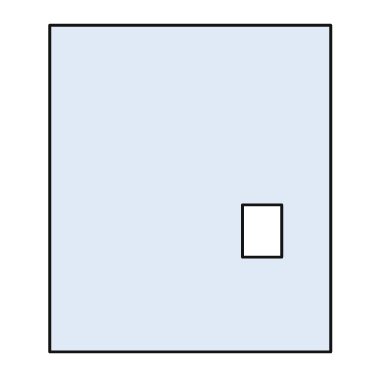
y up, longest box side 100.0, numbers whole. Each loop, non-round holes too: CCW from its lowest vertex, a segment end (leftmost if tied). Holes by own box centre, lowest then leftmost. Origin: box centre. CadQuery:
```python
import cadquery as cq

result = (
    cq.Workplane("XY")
    .moveTo(-43.0, -50.0)
    .lineTo(43.0, -50.0)
    .lineTo(43.0, 50.0)
    .lineTo(-43.0, 50.0)
    .close()
    .moveTo(16.0, -21.0)
    .lineTo(28.0, -21.0)
    .lineTo(28.0, -5.0)
    .lineTo(16.0, -5.0)
    .close()
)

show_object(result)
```